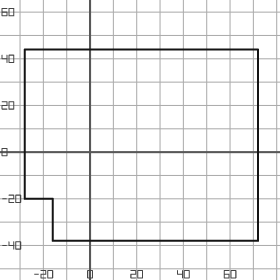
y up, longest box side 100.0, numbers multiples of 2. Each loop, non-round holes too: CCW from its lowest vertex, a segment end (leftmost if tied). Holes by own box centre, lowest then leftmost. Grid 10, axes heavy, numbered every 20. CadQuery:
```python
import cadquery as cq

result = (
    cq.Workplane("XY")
    .moveTo(-16.0, -38.0)
    .lineTo(72.0, -38.0)
    .lineTo(72.0, 44.0)
    .lineTo(-28.0, 44.0)
    .lineTo(-28.0, -20.0)
    .lineTo(-16.0, -20.0)
    .close()
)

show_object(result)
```